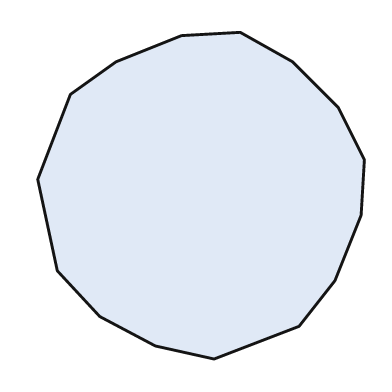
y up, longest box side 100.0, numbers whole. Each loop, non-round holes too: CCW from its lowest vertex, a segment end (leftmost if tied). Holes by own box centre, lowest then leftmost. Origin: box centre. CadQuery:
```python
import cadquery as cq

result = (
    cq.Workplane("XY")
    .moveTo(4.0, -50.0)
    .lineTo(30.0, -40.0)
    .lineTo(41.0, -26.0)
    .lineTo(49.0, -6.0)
    .lineTo(50.0, 11.0)
    .lineTo(42.0, 27.0)
    .lineTo(28.0, 41.0)
    .lineTo(12.0, 50.0)
    .lineTo(-6.0, 49.0)
    .lineTo(-26.0, 41.0)
    .lineTo(-40.0, 31.0)
    .lineTo(-50.0, 5.0)
    .lineTo(-44.0, -23.0)
    .lineTo(-31.0, -37.0)
    .lineTo(-14.0, -46.0)
    .close()
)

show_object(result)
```